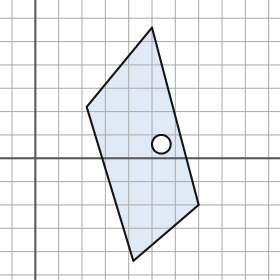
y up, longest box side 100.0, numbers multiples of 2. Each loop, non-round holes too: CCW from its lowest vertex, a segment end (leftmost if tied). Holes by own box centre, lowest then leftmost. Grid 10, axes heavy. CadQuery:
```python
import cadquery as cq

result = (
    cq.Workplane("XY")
    .moveTo(42.0, -44.0)
    .lineTo(70.0, -20.0)
    .lineTo(50.0, 56.0)
    .lineTo(22.0, 22.0)
    .close()
    .moveTo(54.0, 6.0)
    .circle(4.0)
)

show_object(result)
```